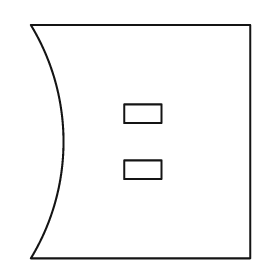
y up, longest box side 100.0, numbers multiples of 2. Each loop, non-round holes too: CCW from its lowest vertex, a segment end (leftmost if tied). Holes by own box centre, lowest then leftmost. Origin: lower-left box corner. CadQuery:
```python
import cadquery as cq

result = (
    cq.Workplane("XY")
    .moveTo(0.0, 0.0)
    .lineTo(94.0, 0.0)
    .lineTo(94.0, 100.0)
    .lineTo(0.0, 100.0)
    .threePointArc((14.0, 50.0), (0.0, 0.0))
    .close()
    .moveTo(40.0, 34.0)
    .lineTo(56.0, 34.0)
    .lineTo(56.0, 42.0)
    .lineTo(40.0, 42.0)
    .close()
    .moveTo(40.0, 58.0)
    .lineTo(56.0, 58.0)
    .lineTo(56.0, 66.0)
    .lineTo(40.0, 66.0)
    .close()
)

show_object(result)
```